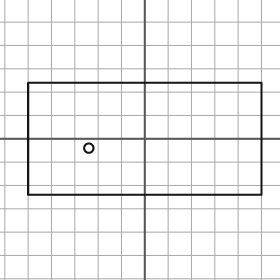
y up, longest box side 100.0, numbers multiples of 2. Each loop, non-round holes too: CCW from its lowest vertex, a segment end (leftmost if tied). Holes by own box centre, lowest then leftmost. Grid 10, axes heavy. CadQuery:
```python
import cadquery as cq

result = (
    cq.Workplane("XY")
    .moveTo(-50.0, -24.0)
    .lineTo(50.0, -24.0)
    .lineTo(50.0, 24.0)
    .lineTo(-50.0, 24.0)
    .close()
    .moveTo(-24.0, -4.0)
    .circle(2.0)
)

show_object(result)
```